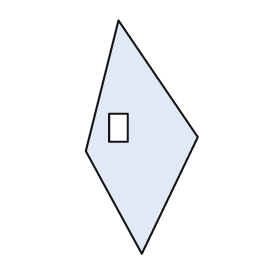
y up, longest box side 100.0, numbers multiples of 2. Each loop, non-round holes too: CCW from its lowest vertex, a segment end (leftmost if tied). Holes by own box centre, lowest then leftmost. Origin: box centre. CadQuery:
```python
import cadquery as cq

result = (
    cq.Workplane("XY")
    .moveTo(0.0, -50.0)
    .lineTo(24.0, 0.0)
    .lineTo(-10.0, 50.0)
    .lineTo(-24.0, -6.0)
    .close()
    .moveTo(-14.0, -2.0)
    .lineTo(-6.0, -2.0)
    .lineTo(-6.0, 10.0)
    .lineTo(-14.0, 10.0)
    .close()
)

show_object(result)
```